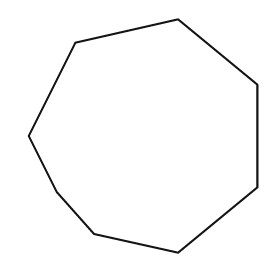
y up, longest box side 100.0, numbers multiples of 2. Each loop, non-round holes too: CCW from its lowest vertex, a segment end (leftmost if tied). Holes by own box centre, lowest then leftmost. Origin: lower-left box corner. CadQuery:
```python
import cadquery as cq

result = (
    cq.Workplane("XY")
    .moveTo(64.0, 0.0)
    .lineTo(98.0, 28.0)
    .lineTo(98.0, 72.0)
    .lineTo(64.0, 100.0)
    .lineTo(20.0, 90.0)
    .lineTo(0.0, 50.0)
    .lineTo(12.0, 26.0)
    .lineTo(28.0, 8.0)
    .close()
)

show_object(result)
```